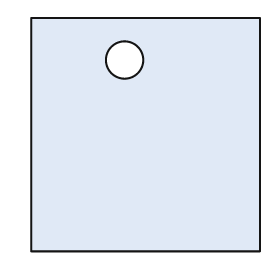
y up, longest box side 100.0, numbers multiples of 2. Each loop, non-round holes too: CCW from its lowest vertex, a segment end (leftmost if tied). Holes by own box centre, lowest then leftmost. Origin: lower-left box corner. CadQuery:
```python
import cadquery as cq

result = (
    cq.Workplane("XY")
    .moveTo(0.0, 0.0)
    .lineTo(98.0, 0.0)
    .lineTo(98.0, 100.0)
    .lineTo(0.0, 100.0)
    .close()
    .moveTo(40.0, 82.0)
    .circle(8.0)
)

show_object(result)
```